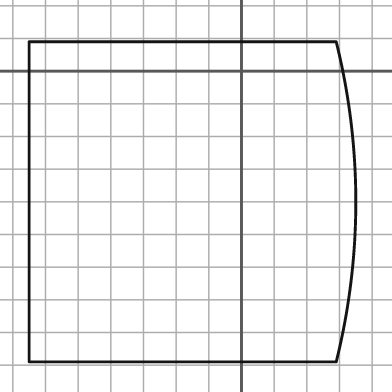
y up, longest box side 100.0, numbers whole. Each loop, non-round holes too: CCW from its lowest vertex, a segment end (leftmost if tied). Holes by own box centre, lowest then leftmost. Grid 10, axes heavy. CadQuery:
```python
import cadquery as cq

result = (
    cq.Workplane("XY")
    .moveTo(-65.0, -89.0)
    .lineTo(29.0, -89.0)
    .threePointArc((35.0, -40.0), (29.0, 9.0))
    .lineTo(-65.0, 9.0)
    .close()
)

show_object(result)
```